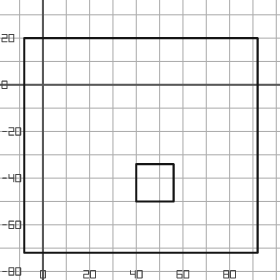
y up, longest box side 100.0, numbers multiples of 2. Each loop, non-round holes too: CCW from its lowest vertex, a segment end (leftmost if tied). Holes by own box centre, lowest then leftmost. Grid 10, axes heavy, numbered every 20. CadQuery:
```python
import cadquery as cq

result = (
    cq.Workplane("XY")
    .moveTo(-8.0, -72.0)
    .lineTo(92.0, -72.0)
    .lineTo(92.0, 20.0)
    .lineTo(-8.0, 20.0)
    .close()
    .moveTo(40.0, -50.0)
    .lineTo(56.0, -50.0)
    .lineTo(56.0, -34.0)
    .lineTo(40.0, -34.0)
    .close()
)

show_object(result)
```